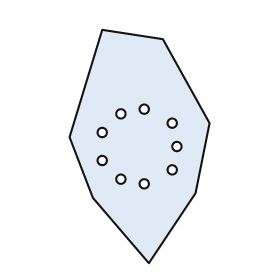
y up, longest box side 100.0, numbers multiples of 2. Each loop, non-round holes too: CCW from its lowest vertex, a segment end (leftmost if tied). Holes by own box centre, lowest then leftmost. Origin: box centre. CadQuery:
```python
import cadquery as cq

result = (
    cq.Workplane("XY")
    .moveTo(4.0, -50.0)
    .lineTo(24.0, -20.0)
    .lineTo(30.0, 10.0)
    .lineTo(10.0, 46.0)
    .lineTo(-16.0, 50.0)
    .lineTo(-30.0, 4.0)
    .lineTo(-20.0, -22.0)
    .close()
    .moveTo(2.0, -16.0)
    .circle(2.0)
    .moveTo(-8.0, -14.0)
    .circle(2.0)
    .moveTo(14.0, -10.0)
    .circle(2.0)
    .moveTo(-16.0, -6.0)
    .circle(2.0)
    .moveTo(16.0, 0.0)
    .circle(2.0)
    .moveTo(-16.0, 6.0)
    .circle(2.0)
    .moveTo(14.0, 10.0)
    .circle(2.0)
    .moveTo(-8.0, 14.0)
    .circle(2.0)
    .moveTo(2.0, 16.0)
    .circle(2.0)
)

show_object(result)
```